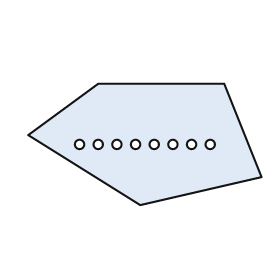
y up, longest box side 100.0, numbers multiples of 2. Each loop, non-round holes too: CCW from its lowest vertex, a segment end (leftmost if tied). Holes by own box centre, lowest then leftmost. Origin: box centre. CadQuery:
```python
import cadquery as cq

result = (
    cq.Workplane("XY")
    .moveTo(-2.0, -26.0)
    .lineTo(50.0, -14.0)
    .lineTo(34.0, 26.0)
    .lineTo(-20.0, 26.0)
    .lineTo(-50.0, 4.0)
    .close()
    .moveTo(-28.0, 0.0)
    .circle(2.0)
    .moveTo(-20.0, 0.0)
    .circle(2.0)
    .moveTo(-12.0, 0.0)
    .circle(2.0)
    .moveTo(-4.0, 0.0)
    .circle(2.0)
    .moveTo(4.0, 0.0)
    .circle(2.0)
    .moveTo(12.0, 0.0)
    .circle(2.0)
    .moveTo(20.0, 0.0)
    .circle(2.0)
    .moveTo(28.0, 0.0)
    .circle(2.0)
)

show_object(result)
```